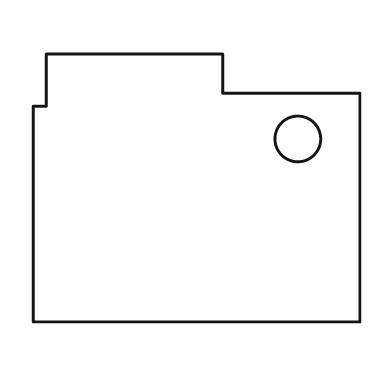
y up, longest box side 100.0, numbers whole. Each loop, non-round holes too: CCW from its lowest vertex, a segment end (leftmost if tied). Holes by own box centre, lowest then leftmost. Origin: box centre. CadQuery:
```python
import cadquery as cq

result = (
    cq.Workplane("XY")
    .moveTo(-50.0, -41.0)
    .lineTo(50.0, -41.0)
    .lineTo(50.0, 29.0)
    .lineTo(8.0, 29.0)
    .lineTo(8.0, 41.0)
    .lineTo(-46.0, 41.0)
    .lineTo(-46.0, 25.0)
    .lineTo(-50.0, 25.0)
    .close()
    .moveTo(31.0, 15.0)
    .circle(7.0)
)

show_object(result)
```